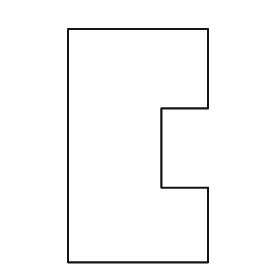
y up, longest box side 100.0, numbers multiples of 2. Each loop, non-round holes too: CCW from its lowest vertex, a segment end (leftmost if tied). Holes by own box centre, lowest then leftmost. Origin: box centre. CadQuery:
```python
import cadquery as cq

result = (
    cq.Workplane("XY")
    .moveTo(-30.0, -50.0)
    .lineTo(30.0, -50.0)
    .lineTo(30.0, -18.0)
    .lineTo(10.0, -18.0)
    .lineTo(10.0, 16.0)
    .lineTo(30.0, 16.0)
    .lineTo(30.0, 50.0)
    .lineTo(-30.0, 50.0)
    .close()
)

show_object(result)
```